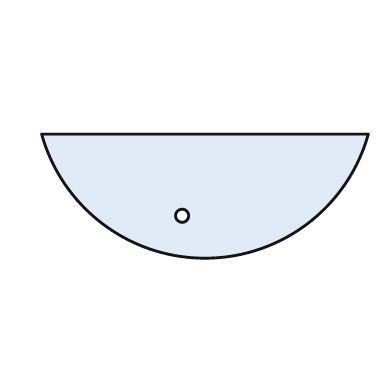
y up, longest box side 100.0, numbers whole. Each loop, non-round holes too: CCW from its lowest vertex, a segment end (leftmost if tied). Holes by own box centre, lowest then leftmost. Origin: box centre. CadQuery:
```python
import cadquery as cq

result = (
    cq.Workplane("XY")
    .moveTo(-50.0, 19.0)
    .threePointArc((0.0, -19.0), (50.0, 19.0))
    .close()
    .moveTo(-7.0, -6.0)
    .circle(2.0)
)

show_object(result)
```